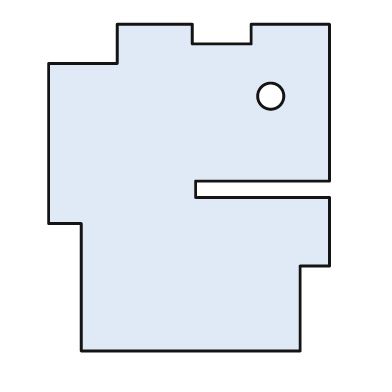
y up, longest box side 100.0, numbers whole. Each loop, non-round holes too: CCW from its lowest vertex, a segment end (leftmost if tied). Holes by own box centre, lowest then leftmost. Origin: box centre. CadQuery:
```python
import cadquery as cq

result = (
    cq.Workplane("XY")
    .moveTo(-33.0, -50.0)
    .lineTo(34.0, -50.0)
    .lineTo(34.0, -24.0)
    .lineTo(43.0, -24.0)
    .lineTo(43.0, -3.0)
    .lineTo(2.0, -3.0)
    .lineTo(2.0, 2.0)
    .lineTo(43.0, 2.0)
    .lineTo(43.0, 50.0)
    .lineTo(19.0, 50.0)
    .lineTo(19.0, 44.0)
    .lineTo(1.0, 44.0)
    .lineTo(1.0, 50.0)
    .lineTo(-22.0, 50.0)
    .lineTo(-22.0, 38.0)
    .lineTo(-43.0, 38.0)
    .lineTo(-43.0, -11.0)
    .lineTo(-33.0, -11.0)
    .close()
    .moveTo(25.0, 28.0)
    .circle(4.0)
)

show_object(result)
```